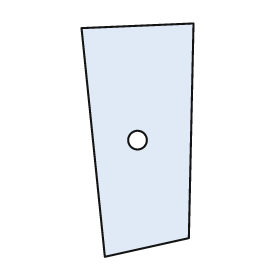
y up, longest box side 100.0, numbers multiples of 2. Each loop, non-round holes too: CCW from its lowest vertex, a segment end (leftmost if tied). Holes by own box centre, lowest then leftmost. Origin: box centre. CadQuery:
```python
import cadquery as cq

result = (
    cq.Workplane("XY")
    .moveTo(-14.0, -50.0)
    .lineTo(22.0, -42.0)
    .lineTo(24.0, 50.0)
    .lineTo(-24.0, 48.0)
    .close()
    .moveTo(0.0, 0.0)
    .circle(4.0)
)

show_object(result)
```